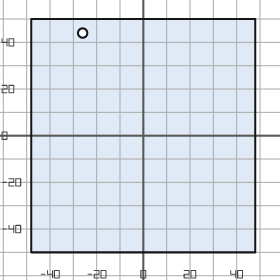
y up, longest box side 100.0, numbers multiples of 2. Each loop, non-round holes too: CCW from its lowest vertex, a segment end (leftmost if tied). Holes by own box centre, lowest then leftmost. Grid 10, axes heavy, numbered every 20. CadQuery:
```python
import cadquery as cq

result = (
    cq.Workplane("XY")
    .moveTo(-48.0, -50.0)
    .lineTo(48.0, -50.0)
    .lineTo(48.0, 50.0)
    .lineTo(-48.0, 50.0)
    .close()
    .moveTo(-26.0, 44.0)
    .circle(2.0)
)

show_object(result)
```